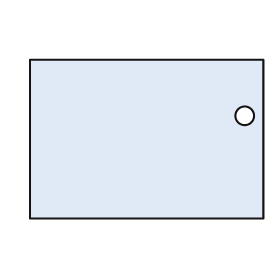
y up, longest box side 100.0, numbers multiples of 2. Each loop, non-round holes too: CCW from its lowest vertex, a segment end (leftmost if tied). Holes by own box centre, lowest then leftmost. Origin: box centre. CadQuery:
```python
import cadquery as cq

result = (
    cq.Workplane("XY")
    .moveTo(-50.0, -34.0)
    .lineTo(50.0, -34.0)
    .lineTo(50.0, 34.0)
    .lineTo(-50.0, 34.0)
    .close()
    .moveTo(42.0, 10.0)
    .circle(4.0)
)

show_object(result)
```